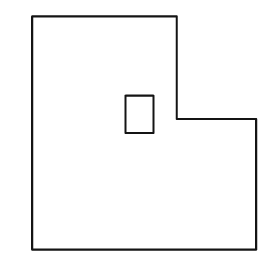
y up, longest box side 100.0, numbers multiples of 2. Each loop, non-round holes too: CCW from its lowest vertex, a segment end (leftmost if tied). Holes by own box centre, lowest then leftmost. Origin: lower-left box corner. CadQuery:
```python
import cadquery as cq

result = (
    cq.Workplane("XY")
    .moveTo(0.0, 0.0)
    .lineTo(96.0, 0.0)
    .lineTo(96.0, 56.0)
    .lineTo(62.0, 56.0)
    .lineTo(62.0, 100.0)
    .lineTo(0.0, 100.0)
    .close()
    .moveTo(40.0, 50.0)
    .lineTo(52.0, 50.0)
    .lineTo(52.0, 66.0)
    .lineTo(40.0, 66.0)
    .close()
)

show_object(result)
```